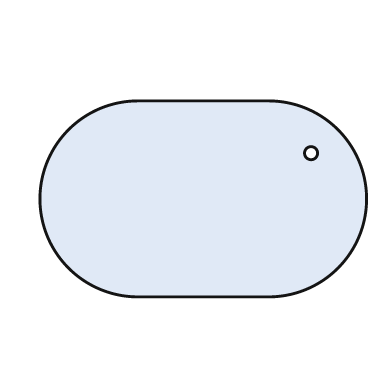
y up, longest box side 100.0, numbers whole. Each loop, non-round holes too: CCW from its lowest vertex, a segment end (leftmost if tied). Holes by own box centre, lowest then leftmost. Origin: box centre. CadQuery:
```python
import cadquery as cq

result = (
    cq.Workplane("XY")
    .moveTo(-20.0, -30.0)
    .lineTo(20.0, -30.0)
    .threePointArc((50.0, 0.0), (20.0, 30.0))
    .lineTo(-20.0, 30.0)
    .threePointArc((-50.0, 0.0), (-20.0, -30.0))
    .close()
    .moveTo(33.0, 14.0)
    .circle(2.0)
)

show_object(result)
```